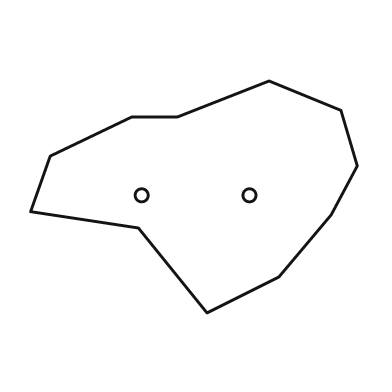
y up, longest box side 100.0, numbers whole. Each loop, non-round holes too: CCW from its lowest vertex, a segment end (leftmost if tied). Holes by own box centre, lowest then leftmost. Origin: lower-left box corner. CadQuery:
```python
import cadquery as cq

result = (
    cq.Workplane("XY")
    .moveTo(54.0, 0.0)
    .lineTo(76.0, 11.0)
    .lineTo(92.0, 30.0)
    .lineTo(100.0, 45.0)
    .lineTo(95.0, 62.0)
    .lineTo(73.0, 71.0)
    .lineTo(45.0, 60.0)
    .lineTo(31.0, 60.0)
    .lineTo(6.0, 48.0)
    .lineTo(0.0, 31.0)
    .lineTo(33.0, 26.0)
    .close()
    .moveTo(34.0, 36.0)
    .circle(2.0)
    .moveTo(67.0, 36.0)
    .circle(2.0)
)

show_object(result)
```